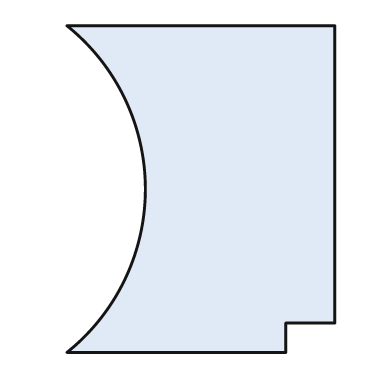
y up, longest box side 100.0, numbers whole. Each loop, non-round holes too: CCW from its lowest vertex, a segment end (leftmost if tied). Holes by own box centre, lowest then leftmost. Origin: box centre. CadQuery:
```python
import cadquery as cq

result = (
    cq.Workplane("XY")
    .moveTo(-41.0, -50.0)
    .lineTo(26.0, -50.0)
    .lineTo(26.0, -41.0)
    .lineTo(41.0, -41.0)
    .lineTo(41.0, 50.0)
    .lineTo(-41.0, 50.0)
    .threePointArc((-17.0, 0.0), (-41.0, -50.0))
    .close()
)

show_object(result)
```